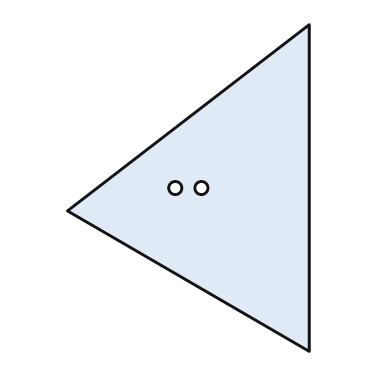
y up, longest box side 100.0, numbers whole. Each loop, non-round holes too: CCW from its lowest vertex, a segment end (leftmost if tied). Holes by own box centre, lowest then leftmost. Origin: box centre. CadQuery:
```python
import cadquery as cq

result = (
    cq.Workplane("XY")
    .moveTo(37.0, -50.0)
    .lineTo(37.0, 50.0)
    .lineTo(-37.0, -7.0)
    .close()
    .moveTo(-4.0, 0.0)
    .circle(2.0)
    .moveTo(4.0, 0.0)
    .circle(2.0)
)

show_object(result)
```